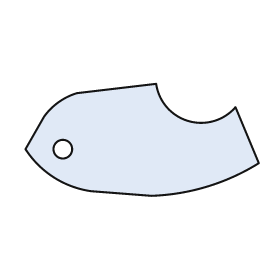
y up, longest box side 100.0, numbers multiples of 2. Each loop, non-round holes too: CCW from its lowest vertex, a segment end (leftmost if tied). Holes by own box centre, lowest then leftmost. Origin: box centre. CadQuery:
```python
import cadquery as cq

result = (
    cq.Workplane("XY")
    .moveTo(4.0, -24.0)
    .threePointArc((28.0, -20.0), (50.0, -10.0))
    .lineTo(40.0, 14.0)
    .threePointArc((20.0, 8.0), (6.0, 24.0))
    .lineTo(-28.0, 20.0)
    .threePointArc((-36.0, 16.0), (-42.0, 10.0))
    .lineTo(-50.0, -4.0)
    .threePointArc((-38.0, -16.0), (-22.0, -22.0))
    .close()
    .moveTo(-34.0, -4.0)
    .circle(4.0)
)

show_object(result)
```